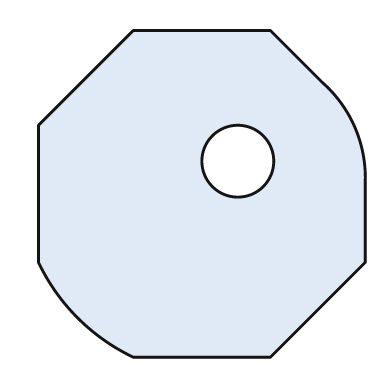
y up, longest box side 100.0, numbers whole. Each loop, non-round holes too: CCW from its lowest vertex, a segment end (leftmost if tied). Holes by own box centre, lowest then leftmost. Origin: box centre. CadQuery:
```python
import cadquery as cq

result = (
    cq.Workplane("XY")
    .moveTo(-21.0, -50.0)
    .lineTo(21.0, -50.0)
    .lineTo(50.0, -21.0)
    .lineTo(50.0, 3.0)
    .threePointArc((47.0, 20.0), (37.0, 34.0))
    .lineTo(21.0, 50.0)
    .lineTo(-21.0, 50.0)
    .lineTo(-50.0, 21.0)
    .lineTo(-50.0, -21.0)
    .threePointArc((-38.0, -38.0), (-21.0, -50.0))
    .close()
    .moveTo(11.0, 10.0)
    .circle(11.0)
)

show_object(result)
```